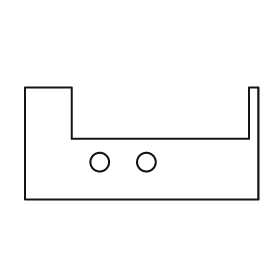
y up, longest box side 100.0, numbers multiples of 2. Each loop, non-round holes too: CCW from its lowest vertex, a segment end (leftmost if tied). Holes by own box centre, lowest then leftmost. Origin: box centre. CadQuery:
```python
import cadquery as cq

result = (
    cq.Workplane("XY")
    .moveTo(-50.0, -24.0)
    .lineTo(50.0, -24.0)
    .lineTo(50.0, 24.0)
    .lineTo(46.0, 24.0)
    .lineTo(46.0, 2.0)
    .lineTo(-30.0, 2.0)
    .lineTo(-30.0, 24.0)
    .lineTo(-50.0, 24.0)
    .close()
    .moveTo(-18.0, -8.0)
    .circle(4.0)
    .moveTo(2.0, -8.0)
    .circle(4.0)
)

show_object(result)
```